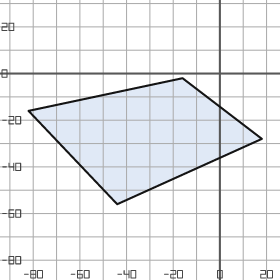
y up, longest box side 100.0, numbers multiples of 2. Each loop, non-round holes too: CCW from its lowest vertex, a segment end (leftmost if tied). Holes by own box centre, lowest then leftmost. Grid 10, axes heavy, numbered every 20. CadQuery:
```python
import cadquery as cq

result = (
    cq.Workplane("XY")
    .moveTo(-44.0, -56.0)
    .lineTo(18.0, -28.0)
    .lineTo(-16.0, -2.0)
    .lineTo(-82.0, -16.0)
    .close()
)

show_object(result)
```